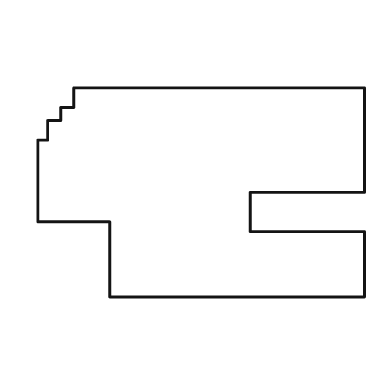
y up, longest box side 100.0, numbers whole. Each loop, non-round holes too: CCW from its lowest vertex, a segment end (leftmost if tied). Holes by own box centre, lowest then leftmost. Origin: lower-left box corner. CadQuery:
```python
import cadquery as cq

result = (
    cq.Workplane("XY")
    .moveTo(22.0, 0.0)
    .lineTo(100.0, 0.0)
    .lineTo(100.0, 20.0)
    .lineTo(65.0, 20.0)
    .lineTo(65.0, 32.0)
    .lineTo(100.0, 32.0)
    .lineTo(100.0, 64.0)
    .lineTo(11.0, 64.0)
    .lineTo(11.0, 58.0)
    .lineTo(7.0, 58.0)
    .lineTo(7.0, 54.0)
    .lineTo(3.0, 54.0)
    .lineTo(3.0, 48.0)
    .lineTo(0.0, 48.0)
    .lineTo(0.0, 23.0)
    .lineTo(22.0, 23.0)
    .close()
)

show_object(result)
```